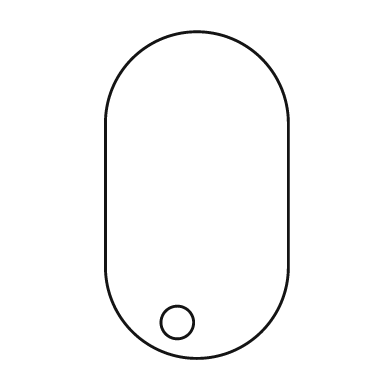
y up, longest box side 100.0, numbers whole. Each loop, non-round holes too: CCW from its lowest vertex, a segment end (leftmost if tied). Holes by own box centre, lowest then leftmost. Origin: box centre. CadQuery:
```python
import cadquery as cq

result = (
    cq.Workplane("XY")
    .moveTo(-28.0, -22.0)
    .threePointArc((0.0, -50.0), (28.0, -22.0))
    .lineTo(28.0, 22.0)
    .threePointArc((0.0, 50.0), (-28.0, 22.0))
    .close()
    .moveTo(-6.0, -39.0)
    .circle(5.0)
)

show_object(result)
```